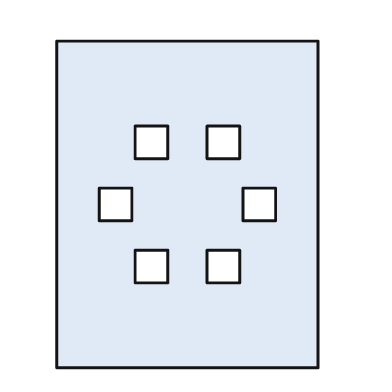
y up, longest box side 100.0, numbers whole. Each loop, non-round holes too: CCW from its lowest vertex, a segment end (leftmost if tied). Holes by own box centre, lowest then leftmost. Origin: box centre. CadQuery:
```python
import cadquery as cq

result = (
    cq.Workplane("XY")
    .moveTo(-40.0, -50.0)
    .lineTo(40.0, -50.0)
    .lineTo(40.0, 50.0)
    .lineTo(-40.0, 50.0)
    .close()
    .moveTo(-16.0, -24.0)
    .lineTo(-6.0, -24.0)
    .lineTo(-6.0, -14.0)
    .lineTo(-16.0, -14.0)
    .close()
    .moveTo(6.0, -24.0)
    .lineTo(16.0, -24.0)
    .lineTo(16.0, -14.0)
    .lineTo(6.0, -14.0)
    .close()
    .moveTo(-27.0, -5.0)
    .lineTo(-17.0, -5.0)
    .lineTo(-17.0, 5.0)
    .lineTo(-27.0, 5.0)
    .close()
    .moveTo(17.0, -5.0)
    .lineTo(27.0, -5.0)
    .lineTo(27.0, 5.0)
    .lineTo(17.0, 5.0)
    .close()
    .moveTo(-16.0, 14.0)
    .lineTo(-6.0, 14.0)
    .lineTo(-6.0, 24.0)
    .lineTo(-16.0, 24.0)
    .close()
    .moveTo(6.0, 14.0)
    .lineTo(16.0, 14.0)
    .lineTo(16.0, 24.0)
    .lineTo(6.0, 24.0)
    .close()
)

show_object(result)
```